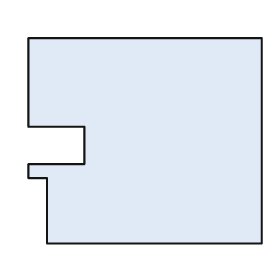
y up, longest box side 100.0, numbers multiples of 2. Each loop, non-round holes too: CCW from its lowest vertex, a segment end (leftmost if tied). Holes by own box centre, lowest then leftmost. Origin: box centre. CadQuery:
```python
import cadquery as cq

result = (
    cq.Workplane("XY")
    .moveTo(-42.0, -44.0)
    .lineTo(50.0, -44.0)
    .lineTo(50.0, 44.0)
    .lineTo(-50.0, 44.0)
    .lineTo(-50.0, 6.0)
    .lineTo(-26.0, 6.0)
    .lineTo(-26.0, -10.0)
    .lineTo(-50.0, -10.0)
    .lineTo(-50.0, -16.0)
    .lineTo(-42.0, -16.0)
    .close()
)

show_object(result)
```